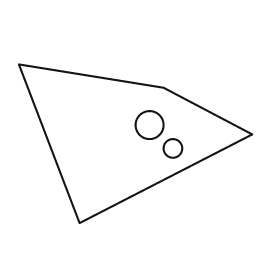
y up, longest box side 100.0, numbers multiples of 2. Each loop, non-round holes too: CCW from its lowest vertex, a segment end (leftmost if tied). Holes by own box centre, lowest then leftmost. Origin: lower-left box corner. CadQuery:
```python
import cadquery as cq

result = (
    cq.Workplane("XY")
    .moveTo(26.0, 0.0)
    .lineTo(100.0, 38.0)
    .lineTo(62.0, 58.0)
    .lineTo(0.0, 68.0)
    .close()
    .moveTo(66.0, 32.0)
    .circle(4.0)
    .moveTo(56.0, 42.0)
    .circle(6.0)
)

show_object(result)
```